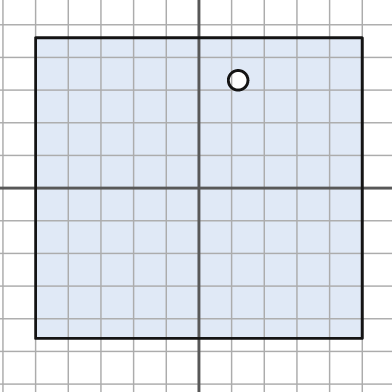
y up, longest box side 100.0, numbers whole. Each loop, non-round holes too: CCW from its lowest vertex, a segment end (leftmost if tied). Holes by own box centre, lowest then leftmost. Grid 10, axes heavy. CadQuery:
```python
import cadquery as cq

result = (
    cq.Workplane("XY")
    .moveTo(-50.0, -46.0)
    .lineTo(50.0, -46.0)
    .lineTo(50.0, 46.0)
    .lineTo(-50.0, 46.0)
    .close()
    .moveTo(12.0, 33.0)
    .circle(3.0)
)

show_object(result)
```